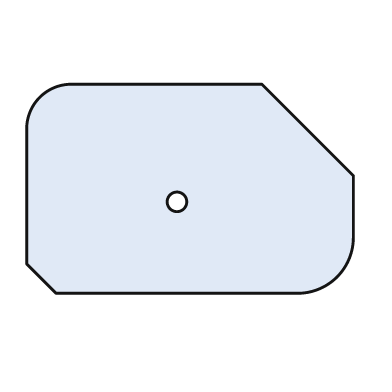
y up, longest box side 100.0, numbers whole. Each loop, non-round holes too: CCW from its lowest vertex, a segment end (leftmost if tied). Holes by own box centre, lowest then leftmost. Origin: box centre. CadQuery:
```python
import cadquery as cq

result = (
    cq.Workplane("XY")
    .moveTo(-41.0, -32.0)
    .lineTo(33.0, -32.0)
    .threePointArc((45.0, -27.0), (50.0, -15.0))
    .lineTo(50.0, 4.0)
    .lineTo(22.0, 32.0)
    .lineTo(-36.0, 32.0)
    .threePointArc((-46.0, 28.0), (-50.0, 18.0))
    .lineTo(-50.0, -23.0)
    .close()
    .moveTo(-4.0, -4.0)
    .circle(3.0)
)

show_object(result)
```